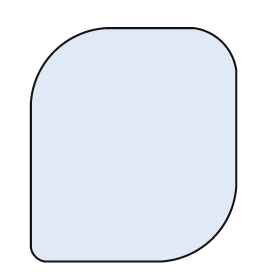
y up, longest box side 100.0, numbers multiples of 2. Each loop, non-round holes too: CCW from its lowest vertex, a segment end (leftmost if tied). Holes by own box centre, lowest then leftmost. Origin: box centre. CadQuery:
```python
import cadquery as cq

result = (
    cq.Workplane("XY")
    .moveTo(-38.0, -50.0)
    .lineTo(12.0, -50.0)
    .threePointArc((34.0, -40.0), (44.0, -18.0))
    .lineTo(44.0, 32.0)
    .threePointArc((38.0, 44.0), (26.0, 50.0))
    .lineTo(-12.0, 50.0)
    .threePointArc((-34.0, 40.0), (-44.0, 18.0))
    .lineTo(-44.0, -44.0)
    .threePointArc((-42.0, -48.0), (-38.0, -50.0))
    .close()
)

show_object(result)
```